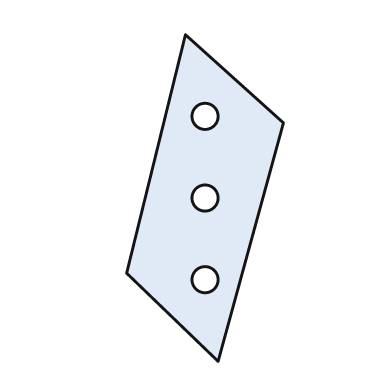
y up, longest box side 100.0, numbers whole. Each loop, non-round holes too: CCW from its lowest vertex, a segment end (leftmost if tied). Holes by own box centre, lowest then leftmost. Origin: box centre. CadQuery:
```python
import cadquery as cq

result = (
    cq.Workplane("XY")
    .moveTo(4.0, -50.0)
    .lineTo(24.0, 23.0)
    .lineTo(-6.0, 50.0)
    .lineTo(-24.0, -23.0)
    .close()
    .moveTo(0.0, -25.0)
    .circle(4.0)
    .moveTo(0.0, 0.0)
    .circle(4.0)
    .moveTo(0.0, 25.0)
    .circle(4.0)
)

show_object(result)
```